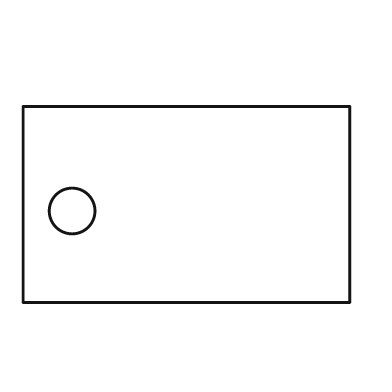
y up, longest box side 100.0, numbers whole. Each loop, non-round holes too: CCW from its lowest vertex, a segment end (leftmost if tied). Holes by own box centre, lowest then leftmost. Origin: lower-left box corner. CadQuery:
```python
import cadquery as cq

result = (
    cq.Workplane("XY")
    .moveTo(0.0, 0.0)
    .lineTo(100.0, 0.0)
    .lineTo(100.0, 60.0)
    .lineTo(0.0, 60.0)
    .close()
    .moveTo(15.0, 28.0)
    .circle(7.0)
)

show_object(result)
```